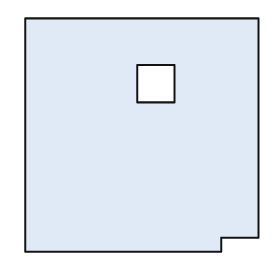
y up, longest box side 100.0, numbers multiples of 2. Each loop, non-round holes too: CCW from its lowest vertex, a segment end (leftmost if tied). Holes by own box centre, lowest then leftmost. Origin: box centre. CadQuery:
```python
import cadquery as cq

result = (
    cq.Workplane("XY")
    .moveTo(-50.0, -50.0)
    .lineTo(34.0, -50.0)
    .lineTo(34.0, -44.0)
    .lineTo(50.0, -44.0)
    .lineTo(50.0, 50.0)
    .lineTo(-50.0, 50.0)
    .close()
    .moveTo(-2.0, 14.0)
    .lineTo(14.0, 14.0)
    .lineTo(14.0, 30.0)
    .lineTo(-2.0, 30.0)
    .close()
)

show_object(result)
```